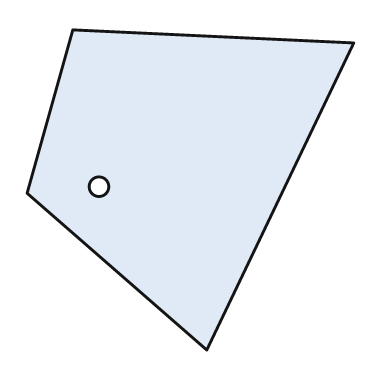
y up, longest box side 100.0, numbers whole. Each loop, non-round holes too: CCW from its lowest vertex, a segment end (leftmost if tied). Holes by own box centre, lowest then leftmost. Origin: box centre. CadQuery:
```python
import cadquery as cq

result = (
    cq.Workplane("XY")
    .moveTo(5.0, -49.0)
    .lineTo(50.0, 45.0)
    .lineTo(-36.0, 49.0)
    .lineTo(-50.0, -1.0)
    .close()
    .moveTo(-28.0, 1.0)
    .circle(3.0)
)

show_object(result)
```